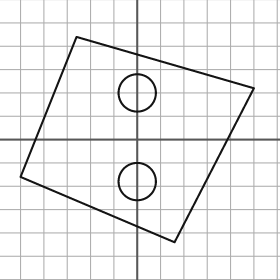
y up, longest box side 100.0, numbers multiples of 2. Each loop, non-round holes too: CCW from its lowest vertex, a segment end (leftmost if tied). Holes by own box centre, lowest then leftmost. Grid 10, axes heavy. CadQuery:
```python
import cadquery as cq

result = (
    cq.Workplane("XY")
    .moveTo(16.0, -44.0)
    .lineTo(50.0, 22.0)
    .lineTo(-26.0, 44.0)
    .lineTo(-50.0, -16.0)
    .close()
    .moveTo(0.0, -18.0)
    .circle(8.0)
    .moveTo(0.0, 20.0)
    .circle(8.0)
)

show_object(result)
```